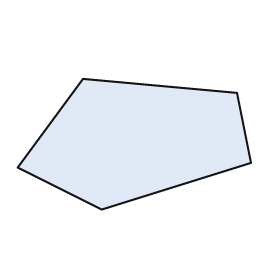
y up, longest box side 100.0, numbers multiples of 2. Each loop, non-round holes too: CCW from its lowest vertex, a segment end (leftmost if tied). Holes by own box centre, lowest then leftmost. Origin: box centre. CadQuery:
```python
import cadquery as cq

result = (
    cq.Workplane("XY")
    .moveTo(-14.0, -28.0)
    .lineTo(50.0, -8.0)
    .lineTo(44.0, 22.0)
    .lineTo(-22.0, 28.0)
    .lineTo(-50.0, -10.0)
    .close()
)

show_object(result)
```